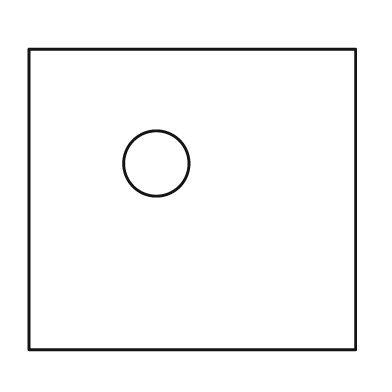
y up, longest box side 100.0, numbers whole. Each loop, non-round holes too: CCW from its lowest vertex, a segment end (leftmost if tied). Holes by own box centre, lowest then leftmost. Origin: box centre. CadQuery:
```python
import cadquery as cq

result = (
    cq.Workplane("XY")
    .moveTo(-50.0, -46.0)
    .lineTo(50.0, -46.0)
    .lineTo(50.0, 46.0)
    .lineTo(-50.0, 46.0)
    .close()
    .moveTo(-11.0, 11.0)
    .circle(10.0)
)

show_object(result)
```